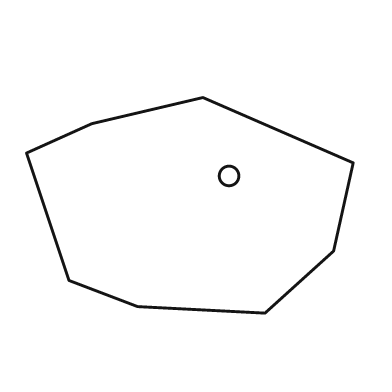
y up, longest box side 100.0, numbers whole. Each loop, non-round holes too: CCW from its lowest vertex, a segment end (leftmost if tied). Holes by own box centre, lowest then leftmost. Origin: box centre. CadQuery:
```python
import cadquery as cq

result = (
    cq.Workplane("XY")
    .moveTo(23.0, -33.0)
    .lineTo(44.0, -14.0)
    .lineTo(50.0, 13.0)
    .lineTo(4.0, 33.0)
    .lineTo(-30.0, 25.0)
    .lineTo(-50.0, 16.0)
    .lineTo(-37.0, -23.0)
    .lineTo(-16.0, -31.0)
    .close()
    .moveTo(12.0, 9.0)
    .circle(3.0)
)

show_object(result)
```